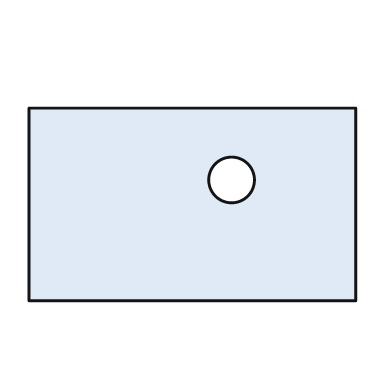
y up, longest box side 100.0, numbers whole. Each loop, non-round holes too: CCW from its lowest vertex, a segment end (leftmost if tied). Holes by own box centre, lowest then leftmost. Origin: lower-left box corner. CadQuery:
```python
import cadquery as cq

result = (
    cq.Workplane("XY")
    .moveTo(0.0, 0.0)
    .lineTo(100.0, 0.0)
    .lineTo(100.0, 59.0)
    .lineTo(0.0, 59.0)
    .close()
    .moveTo(62.0, 37.0)
    .circle(7.0)
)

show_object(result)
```